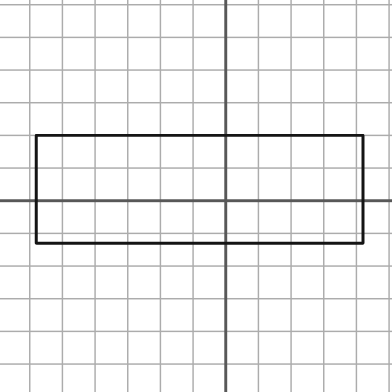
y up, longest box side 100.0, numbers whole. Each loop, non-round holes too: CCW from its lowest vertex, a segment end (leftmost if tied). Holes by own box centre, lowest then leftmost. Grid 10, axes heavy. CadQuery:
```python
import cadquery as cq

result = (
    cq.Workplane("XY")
    .moveTo(-58.0, -13.0)
    .lineTo(42.0, -13.0)
    .lineTo(42.0, 20.0)
    .lineTo(-58.0, 20.0)
    .close()
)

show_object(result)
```